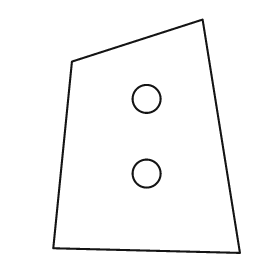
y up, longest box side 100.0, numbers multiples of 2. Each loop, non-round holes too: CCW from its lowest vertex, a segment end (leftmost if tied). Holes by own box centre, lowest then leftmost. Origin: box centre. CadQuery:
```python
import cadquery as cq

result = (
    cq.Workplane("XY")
    .moveTo(40.0, -50.0)
    .lineTo(24.0, 50.0)
    .lineTo(-32.0, 32.0)
    .lineTo(-40.0, -48.0)
    .close()
    .moveTo(0.0, -16.0)
    .circle(6.0)
    .moveTo(0.0, 16.0)
    .circle(6.0)
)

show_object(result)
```